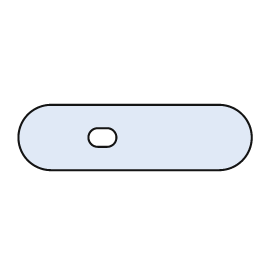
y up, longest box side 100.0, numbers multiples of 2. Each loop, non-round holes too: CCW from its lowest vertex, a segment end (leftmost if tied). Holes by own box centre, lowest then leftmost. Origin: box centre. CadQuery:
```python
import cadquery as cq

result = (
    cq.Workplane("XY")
    .moveTo(-36.0, -14.0)
    .lineTo(36.0, -14.0)
    .threePointArc((50.0, 0.0), (36.0, 14.0))
    .lineTo(-36.0, 14.0)
    .threePointArc((-50.0, 0.0), (-36.0, -14.0))
    .close()
    .moveTo(-16.0, -4.0)
    .lineTo(-12.0, -4.0)
    .threePointArc((-8.0, 0.0), (-12.0, 4.0))
    .lineTo(-16.0, 4.0)
    .threePointArc((-20.0, 0.0), (-16.0, -4.0))
    .close()
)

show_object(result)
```